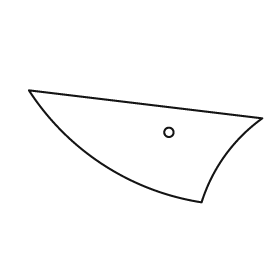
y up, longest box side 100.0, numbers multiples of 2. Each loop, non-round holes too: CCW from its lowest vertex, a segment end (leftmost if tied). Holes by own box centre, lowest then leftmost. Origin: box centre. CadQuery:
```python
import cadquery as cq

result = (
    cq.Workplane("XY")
    .moveTo(24.0, -24.0)
    .threePointArc((34.0, -4.0), (50.0, 12.0))
    .lineTo(-50.0, 24.0)
    .threePointArc((-18.0, -8.0), (24.0, -24.0))
    .close()
    .moveTo(10.0, 6.0)
    .circle(2.0)
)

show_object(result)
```